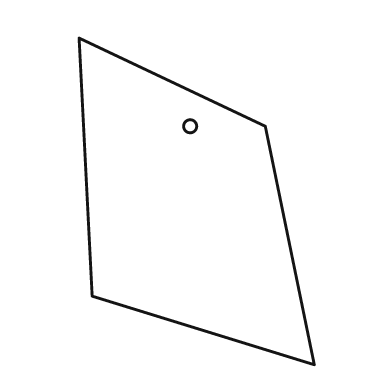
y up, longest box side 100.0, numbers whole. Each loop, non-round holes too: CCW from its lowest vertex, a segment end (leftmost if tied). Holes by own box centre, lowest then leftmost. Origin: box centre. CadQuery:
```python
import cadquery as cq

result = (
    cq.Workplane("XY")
    .moveTo(36.0, -50.0)
    .lineTo(21.0, 23.0)
    .lineTo(-36.0, 50.0)
    .lineTo(-32.0, -29.0)
    .close()
    .moveTo(-2.0, 23.0)
    .circle(2.0)
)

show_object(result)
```